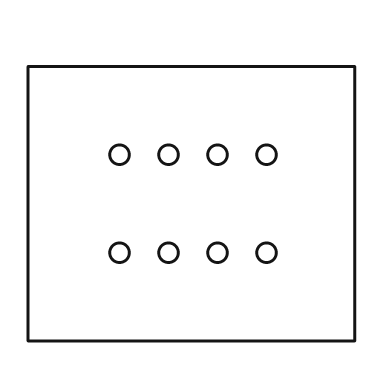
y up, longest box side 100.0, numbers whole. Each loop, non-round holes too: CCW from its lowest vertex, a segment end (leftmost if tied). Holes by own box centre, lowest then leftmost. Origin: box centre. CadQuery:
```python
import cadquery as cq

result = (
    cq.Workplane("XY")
    .moveTo(-50.0, -42.0)
    .lineTo(50.0, -42.0)
    .lineTo(50.0, 42.0)
    .lineTo(-50.0, 42.0)
    .close()
    .moveTo(-22.0, -15.0)
    .circle(3.0)
    .moveTo(-7.0, -15.0)
    .circle(3.0)
    .moveTo(8.0, -15.0)
    .circle(3.0)
    .moveTo(23.0, -15.0)
    .circle(3.0)
    .moveTo(-22.0, 15.0)
    .circle(3.0)
    .moveTo(-7.0, 15.0)
    .circle(3.0)
    .moveTo(8.0, 15.0)
    .circle(3.0)
    .moveTo(23.0, 15.0)
    .circle(3.0)
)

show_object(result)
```